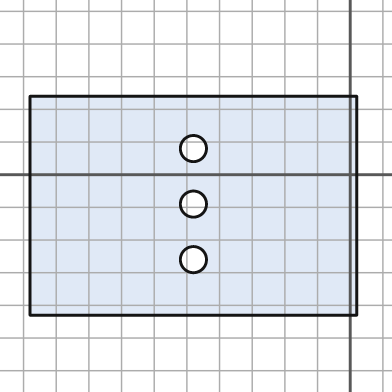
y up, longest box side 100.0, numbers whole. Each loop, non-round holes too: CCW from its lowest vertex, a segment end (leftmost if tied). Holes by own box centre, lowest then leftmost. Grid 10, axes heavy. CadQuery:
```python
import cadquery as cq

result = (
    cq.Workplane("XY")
    .moveTo(-98.0, -43.0)
    .lineTo(2.0, -43.0)
    .lineTo(2.0, 24.0)
    .lineTo(-98.0, 24.0)
    .close()
    .moveTo(-48.0, -26.0)
    .circle(4.0)
    .moveTo(-48.0, -9.0)
    .circle(4.0)
    .moveTo(-48.0, 8.0)
    .circle(4.0)
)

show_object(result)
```